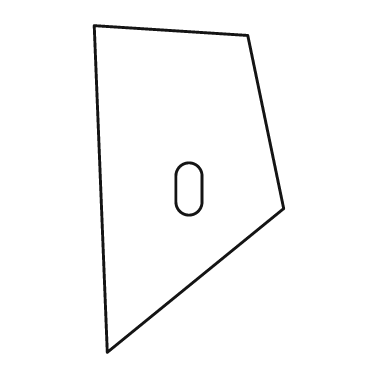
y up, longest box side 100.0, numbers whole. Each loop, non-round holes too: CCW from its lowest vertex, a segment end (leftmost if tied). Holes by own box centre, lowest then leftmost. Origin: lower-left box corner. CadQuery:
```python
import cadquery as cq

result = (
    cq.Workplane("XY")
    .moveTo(4.0, 0.0)
    .lineTo(58.0, 44.0)
    .lineTo(47.0, 97.0)
    .lineTo(0.0, 100.0)
    .close()
    .moveTo(25.0, 46.0)
    .threePointArc((29.0, 42.0), (33.0, 46.0))
    .lineTo(33.0, 54.0)
    .threePointArc((29.0, 58.0), (25.0, 54.0))
    .close()
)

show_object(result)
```